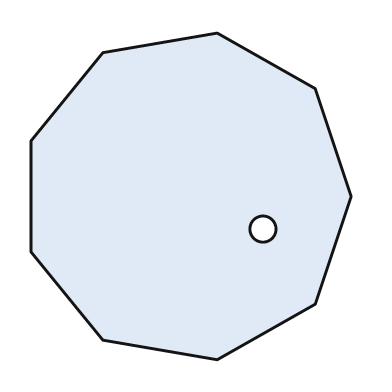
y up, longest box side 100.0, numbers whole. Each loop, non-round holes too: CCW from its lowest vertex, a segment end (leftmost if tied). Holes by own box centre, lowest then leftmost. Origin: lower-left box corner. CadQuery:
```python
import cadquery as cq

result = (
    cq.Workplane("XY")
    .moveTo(57.0, 0.0)
    .lineTo(87.0, 17.0)
    .lineTo(98.0, 50.0)
    .lineTo(87.0, 83.0)
    .lineTo(57.0, 100.0)
    .lineTo(22.0, 94.0)
    .lineTo(0.0, 67.0)
    .lineTo(0.0, 33.0)
    .lineTo(22.0, 6.0)
    .close()
    .moveTo(71.0, 40.0)
    .circle(4.0)
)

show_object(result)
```